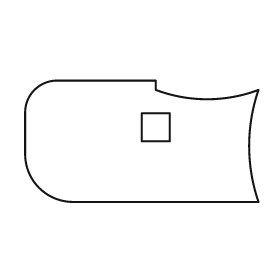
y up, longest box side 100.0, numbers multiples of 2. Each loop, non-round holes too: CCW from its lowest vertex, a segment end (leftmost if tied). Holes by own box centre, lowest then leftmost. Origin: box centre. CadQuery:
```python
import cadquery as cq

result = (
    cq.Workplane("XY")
    .moveTo(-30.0, -26.0)
    .lineTo(50.0, -26.0)
    .threePointArc((46.0, -2.0), (50.0, 22.0))
    .threePointArc((28.0, 18.0), (6.0, 22.0))
    .lineTo(6.0, 26.0)
    .lineTo(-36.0, 26.0)
    .threePointArc((-46.0, 22.0), (-50.0, 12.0))
    .lineTo(-50.0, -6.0)
    .threePointArc((-44.0, -20.0), (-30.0, -26.0))
    .close()
    .moveTo(0.0, 0.0)
    .lineTo(12.0, 0.0)
    .lineTo(12.0, 12.0)
    .lineTo(0.0, 12.0)
    .close()
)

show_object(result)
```